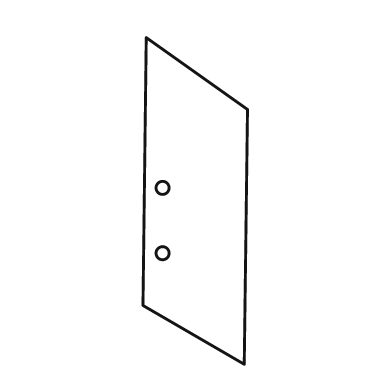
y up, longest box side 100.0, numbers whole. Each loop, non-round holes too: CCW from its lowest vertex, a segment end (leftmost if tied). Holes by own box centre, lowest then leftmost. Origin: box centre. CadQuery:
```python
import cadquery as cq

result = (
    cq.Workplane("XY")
    .moveTo(15.0, -50.0)
    .lineTo(16.0, 28.0)
    .lineTo(-15.0, 50.0)
    .lineTo(-16.0, -32.0)
    .close()
    .moveTo(-10.0, -16.0)
    .circle(2.0)
    .moveTo(-10.0, 4.0)
    .circle(2.0)
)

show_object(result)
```